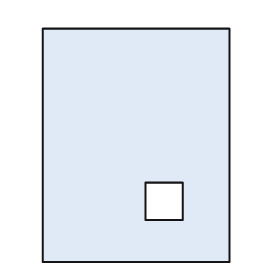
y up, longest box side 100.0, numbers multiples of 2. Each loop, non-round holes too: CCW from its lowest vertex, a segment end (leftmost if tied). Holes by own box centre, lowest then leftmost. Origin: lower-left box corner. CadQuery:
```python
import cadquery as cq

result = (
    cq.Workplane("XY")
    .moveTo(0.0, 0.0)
    .lineTo(80.0, 0.0)
    .lineTo(80.0, 100.0)
    .lineTo(0.0, 100.0)
    .close()
    .moveTo(44.0, 18.0)
    .lineTo(60.0, 18.0)
    .lineTo(60.0, 34.0)
    .lineTo(44.0, 34.0)
    .close()
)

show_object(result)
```